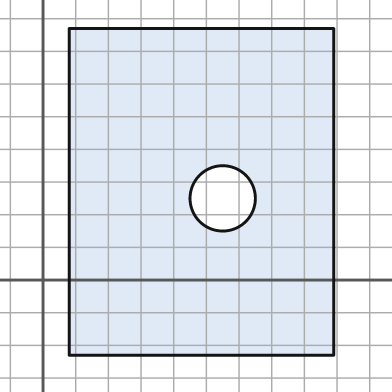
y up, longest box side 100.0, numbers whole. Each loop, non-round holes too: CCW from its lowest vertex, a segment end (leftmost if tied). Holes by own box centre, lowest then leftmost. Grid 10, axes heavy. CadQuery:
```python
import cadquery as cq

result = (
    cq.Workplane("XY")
    .moveTo(8.0, -23.0)
    .lineTo(89.0, -23.0)
    .lineTo(89.0, 77.0)
    .lineTo(8.0, 77.0)
    .close()
    .moveTo(55.0, 25.0)
    .circle(10.0)
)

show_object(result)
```